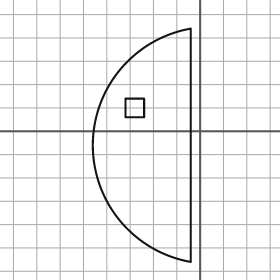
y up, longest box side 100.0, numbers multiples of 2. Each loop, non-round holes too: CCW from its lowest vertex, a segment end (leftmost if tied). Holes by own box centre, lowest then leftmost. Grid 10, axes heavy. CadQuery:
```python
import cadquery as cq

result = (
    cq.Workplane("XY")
    .moveTo(-4.0, -56.0)
    .lineTo(-4.0, 44.0)
    .threePointArc((-46.0, -6.0), (-4.0, -56.0))
    .close()
    .moveTo(-32.0, 6.0)
    .lineTo(-24.0, 6.0)
    .lineTo(-24.0, 14.0)
    .lineTo(-32.0, 14.0)
    .close()
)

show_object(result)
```